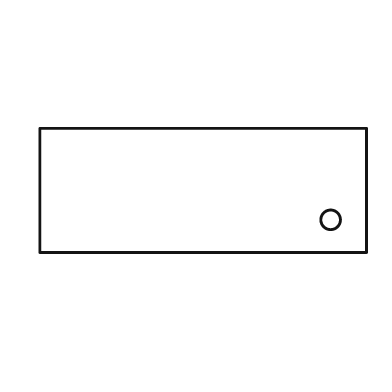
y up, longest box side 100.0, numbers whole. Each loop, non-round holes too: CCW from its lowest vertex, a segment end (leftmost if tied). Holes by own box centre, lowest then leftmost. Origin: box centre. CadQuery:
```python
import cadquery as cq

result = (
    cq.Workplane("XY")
    .moveTo(-50.0, -19.0)
    .lineTo(50.0, -19.0)
    .lineTo(50.0, 19.0)
    .lineTo(-50.0, 19.0)
    .close()
    .moveTo(39.0, -9.0)
    .circle(3.0)
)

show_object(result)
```